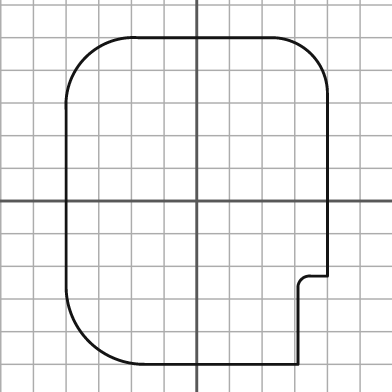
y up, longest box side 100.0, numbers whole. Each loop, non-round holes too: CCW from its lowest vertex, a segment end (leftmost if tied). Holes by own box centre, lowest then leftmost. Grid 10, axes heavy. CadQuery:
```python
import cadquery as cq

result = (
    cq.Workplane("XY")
    .moveTo(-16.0, -50.0)
    .lineTo(31.0, -50.0)
    .lineTo(31.0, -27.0)
    .threePointArc((32.0, -24.0), (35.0, -23.0))
    .lineTo(40.0, -23.0)
    .lineTo(40.0, 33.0)
    .threePointArc((35.0, 45.0), (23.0, 50.0))
    .lineTo(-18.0, 50.0)
    .threePointArc((-34.0, 44.0), (-40.0, 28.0))
    .lineTo(-40.0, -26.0)
    .threePointArc((-33.0, -43.0), (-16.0, -50.0))
    .close()
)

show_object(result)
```